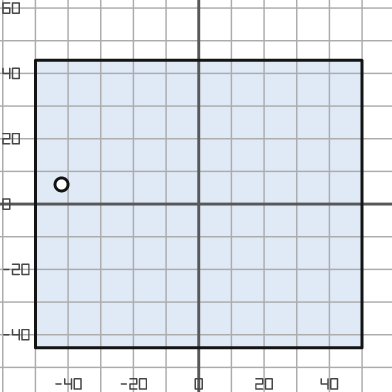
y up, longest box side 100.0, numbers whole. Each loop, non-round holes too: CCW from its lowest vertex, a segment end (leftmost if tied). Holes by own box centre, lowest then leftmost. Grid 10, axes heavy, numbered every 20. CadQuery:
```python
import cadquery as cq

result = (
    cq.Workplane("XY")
    .moveTo(-50.0, -44.0)
    .lineTo(50.0, -44.0)
    .lineTo(50.0, 44.0)
    .lineTo(-50.0, 44.0)
    .close()
    .moveTo(-42.0, 6.0)
    .circle(2.0)
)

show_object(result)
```